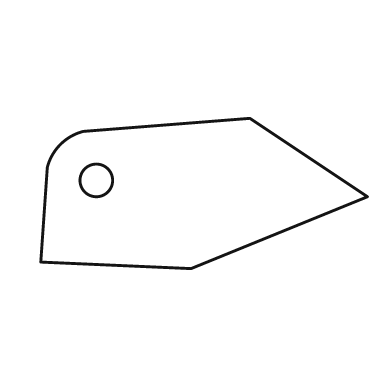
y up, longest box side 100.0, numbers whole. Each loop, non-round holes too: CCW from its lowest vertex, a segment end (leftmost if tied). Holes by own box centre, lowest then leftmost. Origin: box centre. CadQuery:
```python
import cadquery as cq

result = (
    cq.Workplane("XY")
    .moveTo(-4.0, -23.0)
    .lineTo(50.0, -1.0)
    .lineTo(14.0, 23.0)
    .lineTo(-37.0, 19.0)
    .threePointArc((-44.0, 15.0), (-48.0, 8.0))
    .lineTo(-50.0, -21.0)
    .close()
    .moveTo(-33.0, 4.0)
    .circle(5.0)
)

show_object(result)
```